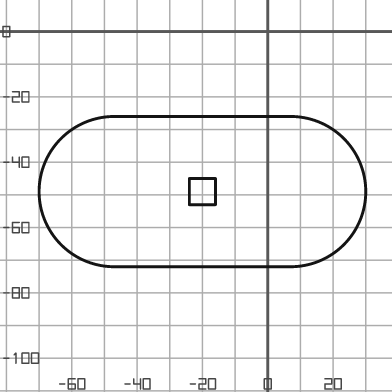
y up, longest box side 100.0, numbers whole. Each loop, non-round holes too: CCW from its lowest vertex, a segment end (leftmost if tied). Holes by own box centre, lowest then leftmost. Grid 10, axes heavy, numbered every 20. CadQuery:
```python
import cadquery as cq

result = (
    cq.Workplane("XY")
    .moveTo(-47.0, -72.0)
    .lineTo(7.0, -72.0)
    .threePointArc((30.0, -49.0), (7.0, -26.0))
    .lineTo(-47.0, -26.0)
    .threePointArc((-70.0, -49.0), (-47.0, -72.0))
    .close()
    .moveTo(-24.0, -53.0)
    .lineTo(-16.0, -53.0)
    .lineTo(-16.0, -45.0)
    .lineTo(-24.0, -45.0)
    .close()
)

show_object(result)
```